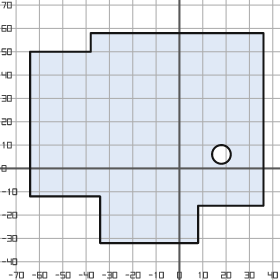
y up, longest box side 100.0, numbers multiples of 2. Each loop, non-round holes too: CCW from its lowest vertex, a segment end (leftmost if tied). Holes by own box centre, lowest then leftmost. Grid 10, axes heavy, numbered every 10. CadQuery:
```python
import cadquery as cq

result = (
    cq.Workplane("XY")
    .moveTo(-34.0, -32.0)
    .lineTo(8.0, -32.0)
    .lineTo(8.0, -16.0)
    .lineTo(36.0, -16.0)
    .lineTo(36.0, 58.0)
    .lineTo(-38.0, 58.0)
    .lineTo(-38.0, 50.0)
    .lineTo(-64.0, 50.0)
    .lineTo(-64.0, -12.0)
    .lineTo(-34.0, -12.0)
    .close()
    .moveTo(18.0, 6.0)
    .circle(4.0)
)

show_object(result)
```